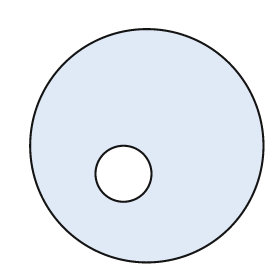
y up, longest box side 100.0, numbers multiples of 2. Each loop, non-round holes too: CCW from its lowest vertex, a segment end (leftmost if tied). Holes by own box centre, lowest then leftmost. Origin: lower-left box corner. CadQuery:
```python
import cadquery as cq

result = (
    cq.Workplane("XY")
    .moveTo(50.0, 50.0)
    .circle(50.0)
    .moveTo(40.0, 38.0)
    .circle(12.0)
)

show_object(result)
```